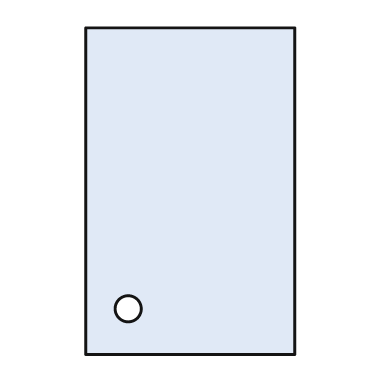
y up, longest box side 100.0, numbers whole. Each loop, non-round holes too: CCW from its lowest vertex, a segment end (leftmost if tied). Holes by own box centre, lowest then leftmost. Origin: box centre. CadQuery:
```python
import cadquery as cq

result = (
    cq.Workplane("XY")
    .moveTo(-32.0, -50.0)
    .lineTo(32.0, -50.0)
    .lineTo(32.0, 50.0)
    .lineTo(-32.0, 50.0)
    .close()
    .moveTo(-19.0, -36.0)
    .circle(4.0)
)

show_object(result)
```